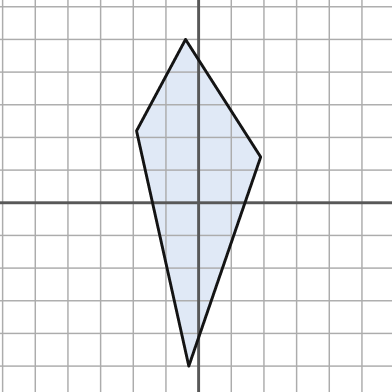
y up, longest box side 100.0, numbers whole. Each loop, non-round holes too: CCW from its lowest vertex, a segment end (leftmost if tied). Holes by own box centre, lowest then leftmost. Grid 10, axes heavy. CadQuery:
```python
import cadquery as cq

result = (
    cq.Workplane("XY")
    .moveTo(-3.0, -50.0)
    .lineTo(19.0, 14.0)
    .lineTo(-4.0, 50.0)
    .lineTo(-19.0, 22.0)
    .close()
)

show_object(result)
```